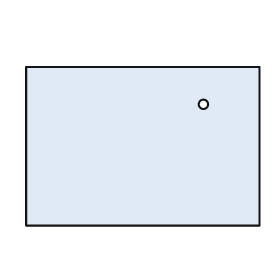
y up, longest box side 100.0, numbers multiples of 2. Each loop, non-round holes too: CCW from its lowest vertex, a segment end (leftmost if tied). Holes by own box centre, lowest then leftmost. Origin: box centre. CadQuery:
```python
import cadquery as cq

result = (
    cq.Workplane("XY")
    .moveTo(-50.0, -34.0)
    .lineTo(50.0, -34.0)
    .lineTo(50.0, 34.0)
    .lineTo(-50.0, 34.0)
    .close()
    .moveTo(26.0, 18.0)
    .circle(2.0)
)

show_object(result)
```